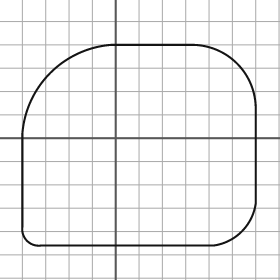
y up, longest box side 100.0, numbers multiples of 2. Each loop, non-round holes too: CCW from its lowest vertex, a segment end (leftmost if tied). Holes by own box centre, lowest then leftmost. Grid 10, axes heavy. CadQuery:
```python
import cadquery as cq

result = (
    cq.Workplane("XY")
    .moveTo(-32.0, -46.0)
    .lineTo(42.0, -46.0)
    .threePointArc((54.0, -40.0), (60.0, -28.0))
    .lineTo(60.0, 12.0)
    .threePointArc((52.0, 32.0), (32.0, 40.0))
    .lineTo(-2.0, 40.0)
    .threePointArc((-28.0, 28.0), (-40.0, 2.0))
    .lineTo(-40.0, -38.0)
    .threePointArc((-38.0, -44.0), (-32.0, -46.0))
    .close()
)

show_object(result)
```